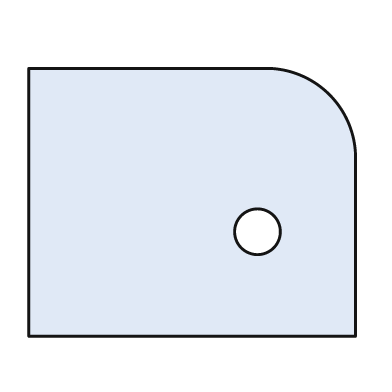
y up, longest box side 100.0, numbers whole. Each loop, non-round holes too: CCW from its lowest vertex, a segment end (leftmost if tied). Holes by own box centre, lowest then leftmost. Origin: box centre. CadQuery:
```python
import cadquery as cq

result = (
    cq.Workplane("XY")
    .moveTo(-50.0, -41.0)
    .lineTo(50.0, -41.0)
    .lineTo(50.0, 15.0)
    .threePointArc((42.0, 33.0), (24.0, 41.0))
    .lineTo(-50.0, 41.0)
    .close()
    .moveTo(20.0, -9.0)
    .circle(7.0)
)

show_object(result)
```